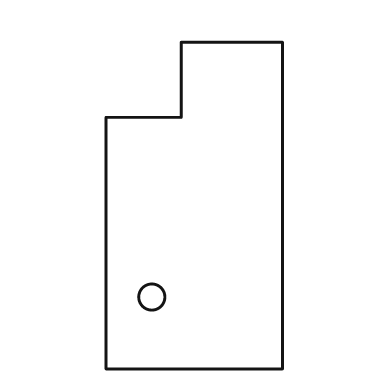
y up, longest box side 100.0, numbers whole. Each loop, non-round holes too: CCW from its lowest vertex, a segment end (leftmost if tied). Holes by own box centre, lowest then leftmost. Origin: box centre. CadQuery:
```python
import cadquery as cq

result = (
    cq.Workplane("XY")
    .moveTo(-27.0, -50.0)
    .lineTo(27.0, -50.0)
    .lineTo(27.0, 50.0)
    .lineTo(-4.0, 50.0)
    .lineTo(-4.0, 27.0)
    .lineTo(-27.0, 27.0)
    .close()
    .moveTo(-13.0, -28.0)
    .circle(4.0)
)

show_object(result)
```